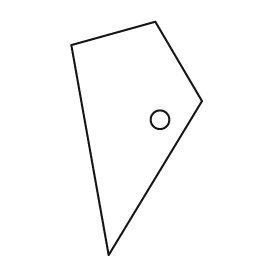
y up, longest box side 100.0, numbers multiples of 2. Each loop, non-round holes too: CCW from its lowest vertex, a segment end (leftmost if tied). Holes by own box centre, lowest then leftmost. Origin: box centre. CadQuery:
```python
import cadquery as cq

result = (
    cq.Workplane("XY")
    .moveTo(-12.0, -50.0)
    .lineTo(28.0, 16.0)
    .lineTo(8.0, 50.0)
    .lineTo(-28.0, 40.0)
    .close()
    .moveTo(10.0, 8.0)
    .circle(4.0)
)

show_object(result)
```